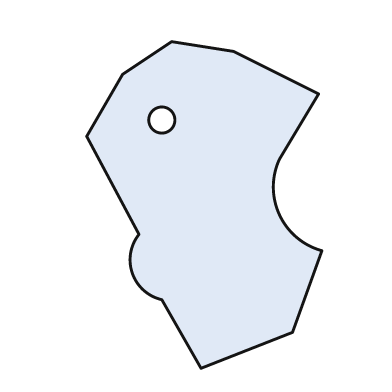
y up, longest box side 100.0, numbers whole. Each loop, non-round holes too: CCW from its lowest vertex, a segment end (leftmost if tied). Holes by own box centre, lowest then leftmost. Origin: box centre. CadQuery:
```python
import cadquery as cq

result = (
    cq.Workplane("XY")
    .moveTo(-1.0, -50.0)
    .lineTo(27.0, -39.0)
    .lineTo(36.0, -14.0)
    .threePointArc((23.0, -3.0), (23.0, 14.0))
    .lineTo(35.0, 34.0)
    .lineTo(9.0, 47.0)
    .lineTo(-10.0, 50.0)
    .lineTo(-25.0, 40.0)
    .lineTo(-36.0, 21.0)
    .lineTo(-20.0, -9.0)
    .threePointArc((-22.0, -21.0), (-13.0, -29.0))
    .close()
    .moveTo(-13.0, 26.0)
    .circle(4.0)
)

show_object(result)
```